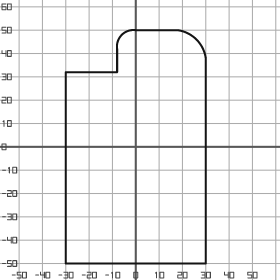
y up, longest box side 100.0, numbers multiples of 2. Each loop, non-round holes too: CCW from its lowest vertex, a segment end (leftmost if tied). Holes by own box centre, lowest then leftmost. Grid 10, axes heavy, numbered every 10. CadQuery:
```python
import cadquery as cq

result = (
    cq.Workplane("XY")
    .moveTo(-30.0, -50.0)
    .lineTo(30.0, -50.0)
    .lineTo(30.0, 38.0)
    .threePointArc((26.0, 46.0), (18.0, 50.0))
    .lineTo(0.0, 50.0)
    .threePointArc((-6.0, 48.0), (-8.0, 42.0))
    .lineTo(-8.0, 32.0)
    .lineTo(-30.0, 32.0)
    .close()
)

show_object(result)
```